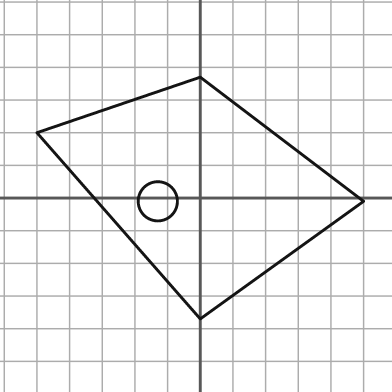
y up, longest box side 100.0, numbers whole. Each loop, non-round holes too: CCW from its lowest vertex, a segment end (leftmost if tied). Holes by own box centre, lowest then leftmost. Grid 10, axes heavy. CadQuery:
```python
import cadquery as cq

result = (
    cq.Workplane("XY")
    .moveTo(0.0, -37.0)
    .lineTo(50.0, -1.0)
    .lineTo(0.0, 37.0)
    .lineTo(-50.0, 20.0)
    .close()
    .moveTo(-13.0, -1.0)
    .circle(6.0)
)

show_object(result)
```